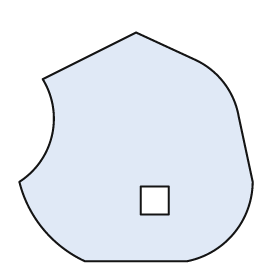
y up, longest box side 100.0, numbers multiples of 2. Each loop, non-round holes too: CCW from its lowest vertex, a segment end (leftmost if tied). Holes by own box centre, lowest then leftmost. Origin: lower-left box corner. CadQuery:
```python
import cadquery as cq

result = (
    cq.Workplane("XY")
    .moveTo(28.0, 0.0)
    .lineTo(72.0, 0.0)
    .threePointArc((92.0, 12.0), (100.0, 34.0))
    .lineTo(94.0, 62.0)
    .threePointArc((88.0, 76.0), (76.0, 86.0))
    .lineTo(50.0, 98.0)
    .lineTo(10.0, 78.0)
    .threePointArc((14.0, 54.0), (0.0, 34.0))
    .threePointArc((10.0, 14.0), (28.0, 0.0))
    .close()
    .moveTo(52.0, 20.0)
    .lineTo(64.0, 20.0)
    .lineTo(64.0, 32.0)
    .lineTo(52.0, 32.0)
    .close()
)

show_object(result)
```